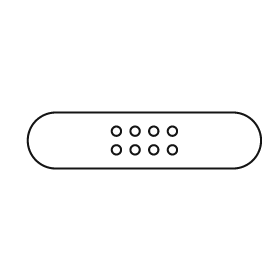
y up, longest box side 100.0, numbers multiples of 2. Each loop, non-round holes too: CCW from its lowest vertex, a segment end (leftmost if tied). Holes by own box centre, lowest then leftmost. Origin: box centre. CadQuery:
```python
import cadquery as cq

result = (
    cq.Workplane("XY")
    .moveTo(-38.0, -12.0)
    .lineTo(38.0, -12.0)
    .threePointArc((50.0, 0.0), (38.0, 12.0))
    .lineTo(-38.0, 12.0)
    .threePointArc((-50.0, 0.0), (-38.0, -12.0))
    .close()
    .moveTo(-12.0, -4.0)
    .circle(2.0)
    .moveTo(-4.0, -4.0)
    .circle(2.0)
    .moveTo(4.0, -4.0)
    .circle(2.0)
    .moveTo(12.0, -4.0)
    .circle(2.0)
    .moveTo(-12.0, 4.0)
    .circle(2.0)
    .moveTo(-4.0, 4.0)
    .circle(2.0)
    .moveTo(4.0, 4.0)
    .circle(2.0)
    .moveTo(12.0, 4.0)
    .circle(2.0)
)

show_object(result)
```